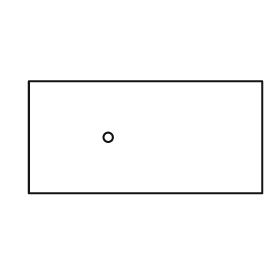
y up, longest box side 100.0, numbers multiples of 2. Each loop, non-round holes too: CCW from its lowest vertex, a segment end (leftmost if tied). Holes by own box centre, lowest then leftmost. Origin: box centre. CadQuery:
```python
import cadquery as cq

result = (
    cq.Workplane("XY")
    .moveTo(-50.0, -24.0)
    .lineTo(50.0, -24.0)
    .lineTo(50.0, 24.0)
    .lineTo(-50.0, 24.0)
    .close()
    .moveTo(-16.0, 0.0)
    .circle(2.0)
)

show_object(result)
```